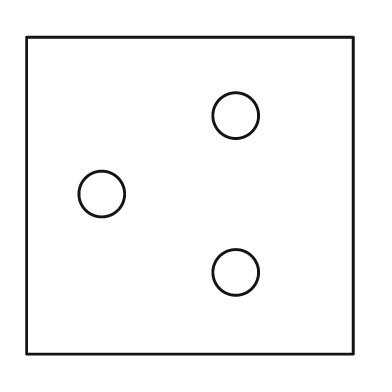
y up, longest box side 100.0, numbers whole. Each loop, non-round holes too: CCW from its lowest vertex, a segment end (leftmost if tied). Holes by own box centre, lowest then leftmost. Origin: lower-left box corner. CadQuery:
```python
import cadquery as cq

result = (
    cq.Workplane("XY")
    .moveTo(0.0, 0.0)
    .lineTo(100.0, 0.0)
    .lineTo(100.0, 97.0)
    .lineTo(0.0, 97.0)
    .close()
    .moveTo(64.0, 25.0)
    .circle(7.0)
    .moveTo(23.0, 49.0)
    .circle(7.0)
    .moveTo(64.0, 73.0)
    .circle(7.0)
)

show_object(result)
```